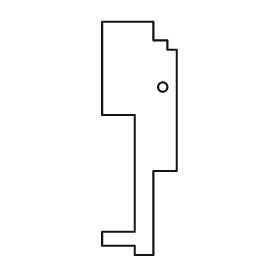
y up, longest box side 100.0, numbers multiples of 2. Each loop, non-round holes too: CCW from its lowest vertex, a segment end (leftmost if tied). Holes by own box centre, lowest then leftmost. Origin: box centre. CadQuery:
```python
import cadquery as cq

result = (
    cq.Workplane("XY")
    .moveTo(-2.0, -50.0)
    .lineTo(6.0, -50.0)
    .lineTo(6.0, -14.0)
    .lineTo(16.0, -14.0)
    .lineTo(16.0, 38.0)
    .lineTo(12.0, 38.0)
    .lineTo(12.0, 42.0)
    .lineTo(6.0, 42.0)
    .lineTo(6.0, 50.0)
    .lineTo(-16.0, 50.0)
    .lineTo(-16.0, 10.0)
    .lineTo(-2.0, 10.0)
    .lineTo(-2.0, -40.0)
    .lineTo(-16.0, -40.0)
    .lineTo(-16.0, -46.0)
    .lineTo(-2.0, -46.0)
    .close()
    .moveTo(10.0, 22.0)
    .circle(2.0)
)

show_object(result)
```